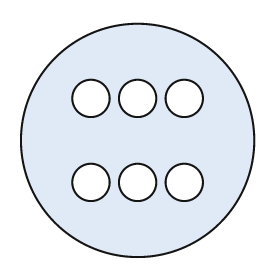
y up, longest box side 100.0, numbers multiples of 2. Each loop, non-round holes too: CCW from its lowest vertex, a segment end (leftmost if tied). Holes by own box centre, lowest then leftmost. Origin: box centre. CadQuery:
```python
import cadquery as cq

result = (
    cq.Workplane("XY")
    .moveTo(0.0, 0.0)
    .circle(50.0)
    .moveTo(-20.0, -18.0)
    .circle(8.0)
    .moveTo(0.0, -18.0)
    .circle(8.0)
    .moveTo(20.0, -18.0)
    .circle(8.0)
    .moveTo(-20.0, 18.0)
    .circle(8.0)
    .moveTo(0.0, 18.0)
    .circle(8.0)
    .moveTo(20.0, 18.0)
    .circle(8.0)
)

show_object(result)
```